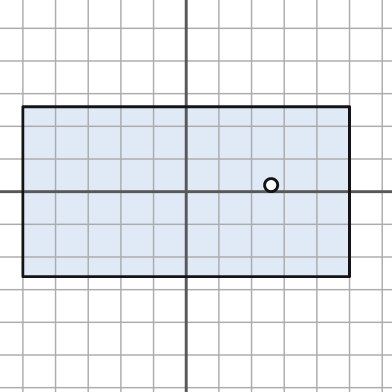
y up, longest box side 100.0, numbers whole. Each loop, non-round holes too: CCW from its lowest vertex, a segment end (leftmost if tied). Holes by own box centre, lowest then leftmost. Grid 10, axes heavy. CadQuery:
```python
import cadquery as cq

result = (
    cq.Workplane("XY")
    .moveTo(-50.0, -26.0)
    .lineTo(50.0, -26.0)
    .lineTo(50.0, 26.0)
    .lineTo(-50.0, 26.0)
    .close()
    .moveTo(26.0, 2.0)
    .circle(2.0)
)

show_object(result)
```